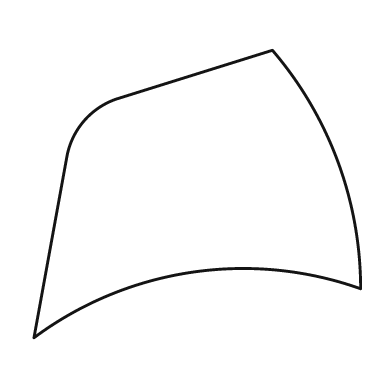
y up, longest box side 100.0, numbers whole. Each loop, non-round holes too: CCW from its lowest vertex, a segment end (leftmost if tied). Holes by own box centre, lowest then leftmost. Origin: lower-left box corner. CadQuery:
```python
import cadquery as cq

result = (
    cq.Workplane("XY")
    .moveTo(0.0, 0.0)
    .threePointArc((48.0, 20.0), (100.0, 15.0))
    .threePointArc((93.0, 54.0), (73.0, 88.0))
    .lineTo(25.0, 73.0)
    .threePointArc((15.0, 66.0), (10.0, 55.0))
    .close()
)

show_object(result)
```